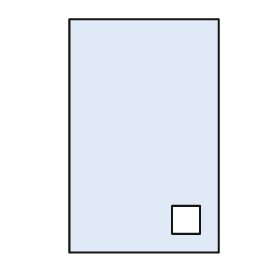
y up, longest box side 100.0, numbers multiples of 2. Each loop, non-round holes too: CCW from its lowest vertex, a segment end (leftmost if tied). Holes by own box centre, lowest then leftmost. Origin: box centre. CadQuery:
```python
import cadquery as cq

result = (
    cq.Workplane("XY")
    .moveTo(-32.0, -50.0)
    .lineTo(32.0, -50.0)
    .lineTo(32.0, 50.0)
    .lineTo(-32.0, 50.0)
    .close()
    .moveTo(12.0, -42.0)
    .lineTo(24.0, -42.0)
    .lineTo(24.0, -30.0)
    .lineTo(12.0, -30.0)
    .close()
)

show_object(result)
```